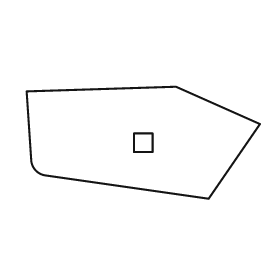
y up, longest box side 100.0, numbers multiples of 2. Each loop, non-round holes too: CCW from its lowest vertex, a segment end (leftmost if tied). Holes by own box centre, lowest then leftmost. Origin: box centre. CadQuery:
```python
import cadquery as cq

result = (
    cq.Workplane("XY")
    .moveTo(28.0, -24.0)
    .lineTo(50.0, 8.0)
    .lineTo(14.0, 24.0)
    .lineTo(-50.0, 22.0)
    .lineTo(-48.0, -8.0)
    .threePointArc((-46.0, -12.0), (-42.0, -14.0))
    .close()
    .moveTo(-4.0, -4.0)
    .lineTo(4.0, -4.0)
    .lineTo(4.0, 4.0)
    .lineTo(-4.0, 4.0)
    .close()
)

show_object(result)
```